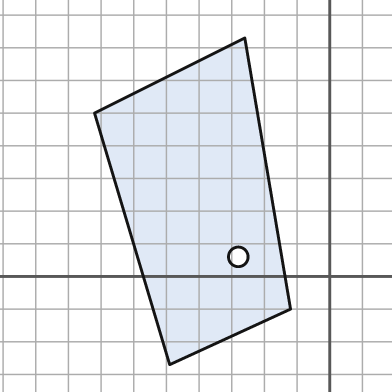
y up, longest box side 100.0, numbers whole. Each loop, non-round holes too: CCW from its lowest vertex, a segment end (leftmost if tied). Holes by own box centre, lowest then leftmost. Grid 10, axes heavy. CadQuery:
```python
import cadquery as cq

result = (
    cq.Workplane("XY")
    .moveTo(-49.0, -27.0)
    .lineTo(-12.0, -10.0)
    .lineTo(-26.0, 73.0)
    .lineTo(-72.0, 50.0)
    .close()
    .moveTo(-28.0, 6.0)
    .circle(3.0)
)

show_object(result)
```